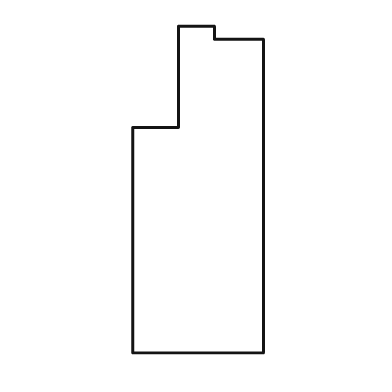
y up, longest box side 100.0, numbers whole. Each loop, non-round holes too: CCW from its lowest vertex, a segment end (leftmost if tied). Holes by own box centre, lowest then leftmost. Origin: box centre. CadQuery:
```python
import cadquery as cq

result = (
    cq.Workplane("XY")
    .moveTo(-20.0, -50.0)
    .lineTo(20.0, -50.0)
    .lineTo(20.0, 46.0)
    .lineTo(5.0, 46.0)
    .lineTo(5.0, 50.0)
    .lineTo(-6.0, 50.0)
    .lineTo(-6.0, 19.0)
    .lineTo(-20.0, 19.0)
    .close()
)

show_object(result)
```